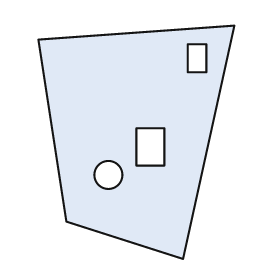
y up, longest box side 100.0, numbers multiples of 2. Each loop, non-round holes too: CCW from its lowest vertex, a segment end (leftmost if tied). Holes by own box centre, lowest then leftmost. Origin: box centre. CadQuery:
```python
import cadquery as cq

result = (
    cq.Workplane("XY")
    .moveTo(20.0, -50.0)
    .lineTo(42.0, 50.0)
    .lineTo(-42.0, 44.0)
    .lineTo(-30.0, -34.0)
    .close()
    .moveTo(-12.0, -14.0)
    .circle(6.0)
    .moveTo(0.0, -10.0)
    .lineTo(12.0, -10.0)
    .lineTo(12.0, 6.0)
    .lineTo(0.0, 6.0)
    .close()
    .moveTo(22.0, 30.0)
    .lineTo(30.0, 30.0)
    .lineTo(30.0, 42.0)
    .lineTo(22.0, 42.0)
    .close()
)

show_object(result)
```